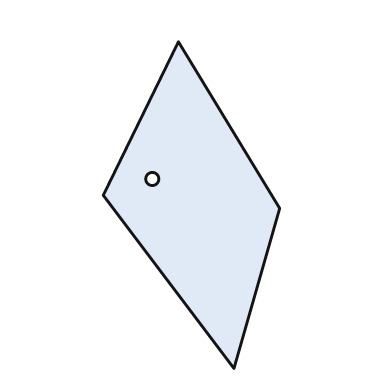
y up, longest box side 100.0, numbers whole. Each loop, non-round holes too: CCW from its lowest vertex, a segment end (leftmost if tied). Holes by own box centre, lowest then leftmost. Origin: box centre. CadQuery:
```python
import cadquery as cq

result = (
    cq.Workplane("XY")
    .moveTo(13.0, -50.0)
    .lineTo(27.0, -1.0)
    .lineTo(-4.0, 50.0)
    .lineTo(-27.0, 3.0)
    .close()
    .moveTo(-12.0, 8.0)
    .circle(2.0)
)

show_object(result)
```